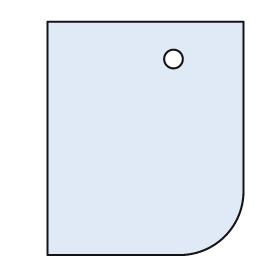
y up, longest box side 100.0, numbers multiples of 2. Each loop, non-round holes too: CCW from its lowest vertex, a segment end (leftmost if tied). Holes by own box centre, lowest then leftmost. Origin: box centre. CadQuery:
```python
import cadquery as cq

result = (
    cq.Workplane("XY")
    .moveTo(-42.0, -50.0)
    .lineTo(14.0, -50.0)
    .threePointArc((34.0, -42.0), (42.0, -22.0))
    .lineTo(42.0, 50.0)
    .lineTo(-42.0, 50.0)
    .close()
    .moveTo(12.0, 34.0)
    .circle(4.0)
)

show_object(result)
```